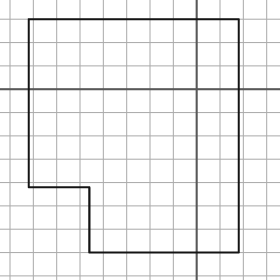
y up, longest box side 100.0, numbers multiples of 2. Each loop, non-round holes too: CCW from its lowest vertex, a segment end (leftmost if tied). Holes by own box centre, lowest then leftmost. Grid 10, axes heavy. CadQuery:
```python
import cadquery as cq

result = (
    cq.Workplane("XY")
    .moveTo(-46.0, -70.0)
    .lineTo(18.0, -70.0)
    .lineTo(18.0, 30.0)
    .lineTo(-72.0, 30.0)
    .lineTo(-72.0, -42.0)
    .lineTo(-46.0, -42.0)
    .close()
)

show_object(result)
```